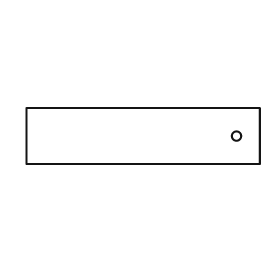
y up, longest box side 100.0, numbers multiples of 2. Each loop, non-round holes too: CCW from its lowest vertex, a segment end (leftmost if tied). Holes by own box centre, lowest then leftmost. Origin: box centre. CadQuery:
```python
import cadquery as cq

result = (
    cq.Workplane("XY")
    .moveTo(-50.0, -12.0)
    .lineTo(50.0, -12.0)
    .lineTo(50.0, 12.0)
    .lineTo(-50.0, 12.0)
    .close()
    .moveTo(40.0, 0.0)
    .circle(2.0)
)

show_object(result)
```